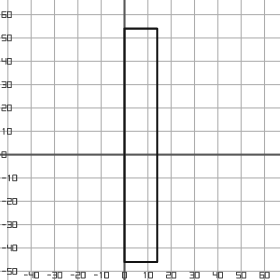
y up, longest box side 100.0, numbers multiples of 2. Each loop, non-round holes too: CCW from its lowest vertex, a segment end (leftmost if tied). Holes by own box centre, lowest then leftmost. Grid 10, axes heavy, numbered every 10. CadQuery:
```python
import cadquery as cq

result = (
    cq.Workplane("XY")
    .moveTo(0.0, -46.0)
    .lineTo(14.0, -46.0)
    .lineTo(14.0, 54.0)
    .lineTo(0.0, 54.0)
    .close()
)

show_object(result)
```